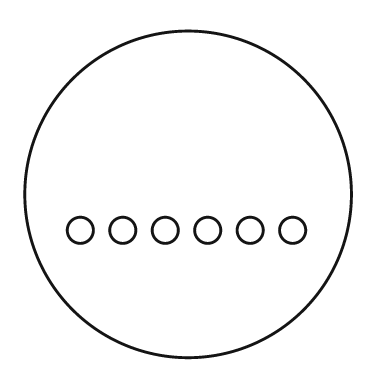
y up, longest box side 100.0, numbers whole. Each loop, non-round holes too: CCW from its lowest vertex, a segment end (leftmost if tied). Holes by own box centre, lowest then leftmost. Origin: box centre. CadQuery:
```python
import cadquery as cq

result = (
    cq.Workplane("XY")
    .moveTo(0.0, 0.0)
    .circle(50.0)
    .moveTo(-33.0, -11.0)
    .circle(4.0)
    .moveTo(-20.0, -11.0)
    .circle(4.0)
    .moveTo(-7.0, -11.0)
    .circle(4.0)
    .moveTo(6.0, -11.0)
    .circle(4.0)
    .moveTo(19.0, -11.0)
    .circle(4.0)
    .moveTo(32.0, -11.0)
    .circle(4.0)
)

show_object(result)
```